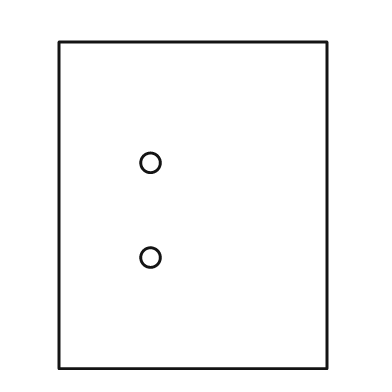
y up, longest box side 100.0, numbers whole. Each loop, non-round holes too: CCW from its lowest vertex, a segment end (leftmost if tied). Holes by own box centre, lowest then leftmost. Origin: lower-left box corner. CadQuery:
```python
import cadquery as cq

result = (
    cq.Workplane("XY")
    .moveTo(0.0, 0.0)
    .lineTo(82.0, 0.0)
    .lineTo(82.0, 100.0)
    .lineTo(0.0, 100.0)
    .close()
    .moveTo(28.0, 34.0)
    .circle(3.0)
    .moveTo(28.0, 63.0)
    .circle(3.0)
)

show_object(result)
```